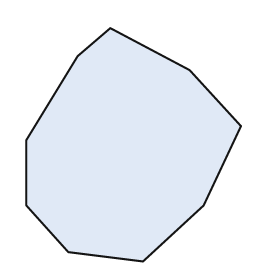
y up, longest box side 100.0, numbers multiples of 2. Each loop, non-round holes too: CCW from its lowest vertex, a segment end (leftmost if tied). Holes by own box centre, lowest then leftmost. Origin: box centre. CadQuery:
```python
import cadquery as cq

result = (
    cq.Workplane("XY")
    .moveTo(4.0, -50.0)
    .lineTo(30.0, -26.0)
    .lineTo(46.0, 8.0)
    .lineTo(24.0, 32.0)
    .lineTo(-10.0, 50.0)
    .lineTo(-24.0, 38.0)
    .lineTo(-46.0, 2.0)
    .lineTo(-46.0, -26.0)
    .lineTo(-28.0, -46.0)
    .close()
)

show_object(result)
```